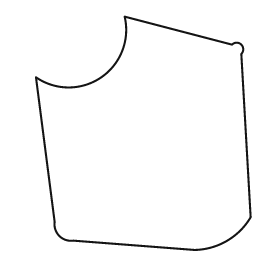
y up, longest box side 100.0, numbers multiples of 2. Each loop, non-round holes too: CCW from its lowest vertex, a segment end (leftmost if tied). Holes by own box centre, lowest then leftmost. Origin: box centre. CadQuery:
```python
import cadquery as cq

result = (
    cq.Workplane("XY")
    .moveTo(22.0, -50.0)
    .threePointArc((36.0, -46.0), (46.0, -36.0))
    .lineTo(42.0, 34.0)
    .threePointArc((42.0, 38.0), (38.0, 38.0))
    .lineTo(-8.0, 50.0)
    .threePointArc((-18.0, 24.0), (-46.0, 24.0))
    .lineTo(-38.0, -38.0)
    .threePointArc((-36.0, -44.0), (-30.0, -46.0))
    .close()
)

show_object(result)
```